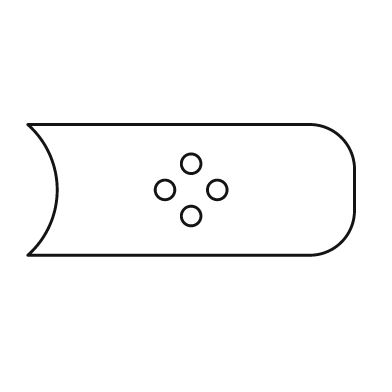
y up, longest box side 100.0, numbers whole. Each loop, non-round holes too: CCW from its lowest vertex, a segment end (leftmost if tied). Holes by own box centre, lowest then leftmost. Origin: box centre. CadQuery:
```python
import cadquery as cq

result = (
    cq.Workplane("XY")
    .moveTo(-50.0, -20.0)
    .lineTo(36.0, -20.0)
    .threePointArc((46.0, -16.0), (50.0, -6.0))
    .lineTo(50.0, 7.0)
    .threePointArc((46.0, 16.0), (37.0, 20.0))
    .lineTo(-50.0, 20.0)
    .threePointArc((-41.0, 0.0), (-50.0, -20.0))
    .close()
    .moveTo(0.0, -8.0)
    .circle(3.0)
    .moveTo(-8.0, 0.0)
    .circle(3.0)
    .moveTo(8.0, 0.0)
    .circle(3.0)
    .moveTo(0.0, 8.0)
    .circle(3.0)
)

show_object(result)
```